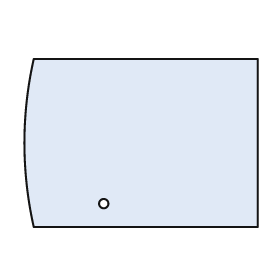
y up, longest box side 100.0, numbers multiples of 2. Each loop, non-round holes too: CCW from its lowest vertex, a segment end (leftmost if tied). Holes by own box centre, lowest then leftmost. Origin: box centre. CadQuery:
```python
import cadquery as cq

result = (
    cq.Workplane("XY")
    .moveTo(-46.0, -36.0)
    .lineTo(50.0, -36.0)
    .lineTo(50.0, 36.0)
    .lineTo(-46.0, 36.0)
    .threePointArc((-50.0, 0.0), (-46.0, -36.0))
    .close()
    .moveTo(-16.0, -26.0)
    .circle(2.0)
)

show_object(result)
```